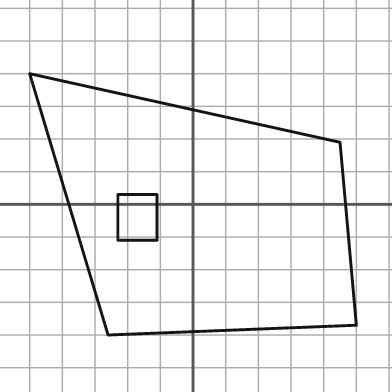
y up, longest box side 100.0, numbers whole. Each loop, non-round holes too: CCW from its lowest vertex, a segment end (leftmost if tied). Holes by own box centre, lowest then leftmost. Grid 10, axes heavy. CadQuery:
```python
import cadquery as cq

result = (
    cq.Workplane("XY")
    .moveTo(-26.0, -40.0)
    .lineTo(50.0, -37.0)
    .lineTo(45.0, 19.0)
    .lineTo(-50.0, 40.0)
    .close()
    .moveTo(-23.0, -11.0)
    .lineTo(-11.0, -11.0)
    .lineTo(-11.0, 3.0)
    .lineTo(-23.0, 3.0)
    .close()
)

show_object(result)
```